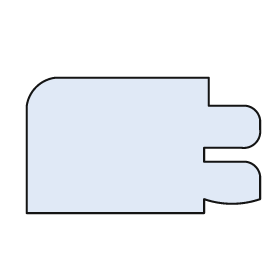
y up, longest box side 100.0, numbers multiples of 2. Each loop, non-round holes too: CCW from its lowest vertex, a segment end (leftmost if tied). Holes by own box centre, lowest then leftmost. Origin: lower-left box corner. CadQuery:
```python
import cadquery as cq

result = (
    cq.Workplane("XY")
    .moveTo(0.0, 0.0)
    .lineTo(76.0, 0.0)
    .lineTo(76.0, 6.0)
    .threePointArc((88.0, 4.0), (100.0, 6.0))
    .lineTo(100.0, 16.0)
    .threePointArc((98.0, 20.0), (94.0, 22.0))
    .lineTo(76.0, 22.0)
    .lineTo(76.0, 28.0)
    .lineTo(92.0, 28.0)
    .threePointArc((98.0, 30.0), (100.0, 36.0))
    .lineTo(100.0, 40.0)
    .threePointArc((98.0, 44.0), (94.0, 46.0))
    .lineTo(78.0, 46.0)
    .lineTo(78.0, 58.0)
    .lineTo(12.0, 58.0)
    .threePointArc((4.0, 54.0), (0.0, 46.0))
    .close()
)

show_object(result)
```